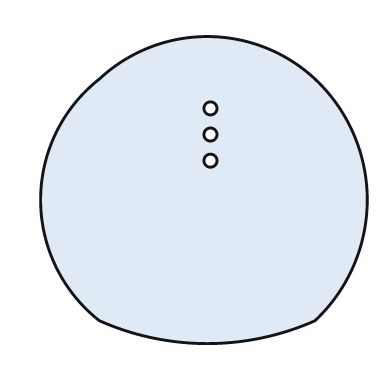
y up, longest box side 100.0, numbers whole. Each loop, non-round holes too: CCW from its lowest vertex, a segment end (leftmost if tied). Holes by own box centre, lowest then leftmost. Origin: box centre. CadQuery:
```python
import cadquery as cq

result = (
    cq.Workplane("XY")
    .moveTo(-32.0, -40.0)
    .threePointArc((1.0, -47.0), (34.0, -40.0))
    .threePointArc((50.0, -3.0), (34.0, 34.0))
    .threePointArc((1.0, 47.0), (-32.0, 34.0))
    .threePointArc((-50.0, -3.0), (-32.0, -40.0))
    .close()
    .moveTo(2.0, 9.0)
    .circle(2.0)
    .moveTo(2.0, 17.0)
    .circle(2.0)
    .moveTo(2.0, 25.0)
    .circle(2.0)
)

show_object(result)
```